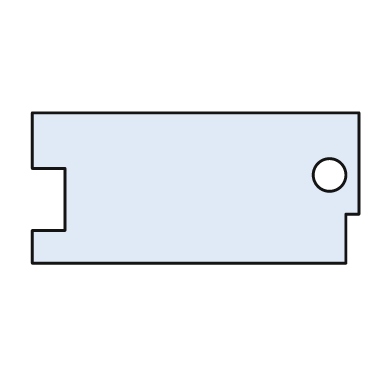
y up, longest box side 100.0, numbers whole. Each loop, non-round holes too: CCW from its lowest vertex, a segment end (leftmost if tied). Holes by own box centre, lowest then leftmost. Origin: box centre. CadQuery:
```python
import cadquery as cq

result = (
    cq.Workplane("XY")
    .moveTo(-50.0, -23.0)
    .lineTo(46.0, -23.0)
    .lineTo(46.0, -8.0)
    .lineTo(50.0, -8.0)
    .lineTo(50.0, 23.0)
    .lineTo(-50.0, 23.0)
    .lineTo(-50.0, 6.0)
    .lineTo(-40.0, 6.0)
    .lineTo(-40.0, -13.0)
    .lineTo(-50.0, -13.0)
    .close()
    .moveTo(41.0, 4.0)
    .circle(5.0)
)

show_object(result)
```